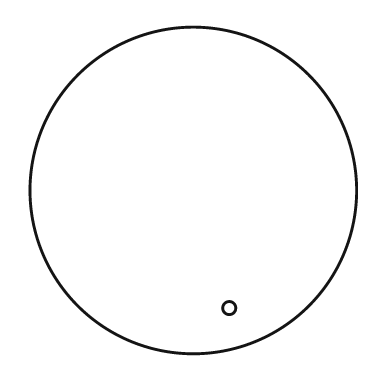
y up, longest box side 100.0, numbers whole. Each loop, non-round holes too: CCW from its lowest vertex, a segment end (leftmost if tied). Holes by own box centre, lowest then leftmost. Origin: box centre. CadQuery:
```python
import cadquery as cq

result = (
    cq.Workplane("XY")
    .moveTo(0.0, 0.0)
    .circle(50.0)
    .moveTo(11.0, -36.0)
    .circle(2.0)
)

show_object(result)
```